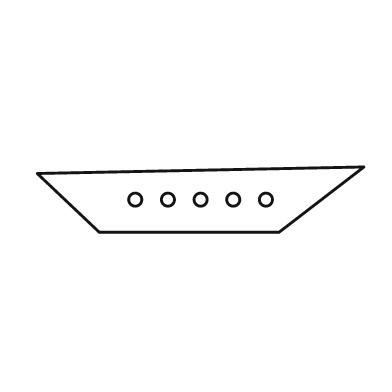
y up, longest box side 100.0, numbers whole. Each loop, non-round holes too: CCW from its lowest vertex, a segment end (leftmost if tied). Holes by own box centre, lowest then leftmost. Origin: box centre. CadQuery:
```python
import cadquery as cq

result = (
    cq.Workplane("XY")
    .moveTo(-31.0, -10.0)
    .lineTo(24.0, -10.0)
    .lineTo(50.0, 10.0)
    .lineTo(-50.0, 8.0)
    .close()
    .moveTo(-20.0, 0.0)
    .circle(2.0)
    .moveTo(-10.0, 0.0)
    .circle(2.0)
    .moveTo(0.0, 0.0)
    .circle(2.0)
    .moveTo(10.0, 0.0)
    .circle(2.0)
    .moveTo(20.0, 0.0)
    .circle(2.0)
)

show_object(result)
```